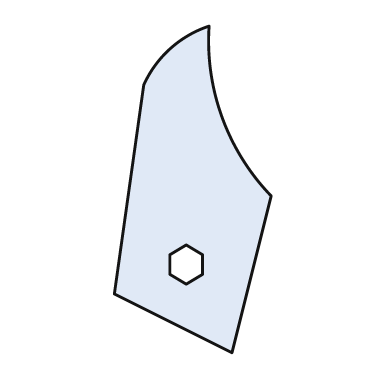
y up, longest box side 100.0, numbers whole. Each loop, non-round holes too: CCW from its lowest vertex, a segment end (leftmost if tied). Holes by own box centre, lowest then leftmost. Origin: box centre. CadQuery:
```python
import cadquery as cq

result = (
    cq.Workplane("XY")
    .moveTo(12.0, -50.0)
    .lineTo(24.0, -2.0)
    .threePointArc((9.0, 22.0), (5.0, 50.0))
    .threePointArc((-7.0, 43.0), (-15.0, 32.0))
    .lineTo(-24.0, -32.0)
    .close()
    .moveTo(-2.0, -29.0)
    .lineTo(3.0, -26.0)
    .lineTo(3.0, -20.0)
    .lineTo(-2.0, -17.0)
    .lineTo(-7.0, -20.0)
    .lineTo(-7.0, -26.0)
    .close()
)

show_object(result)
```